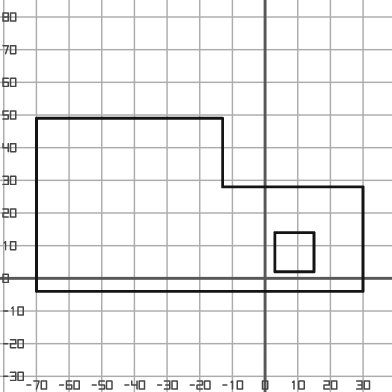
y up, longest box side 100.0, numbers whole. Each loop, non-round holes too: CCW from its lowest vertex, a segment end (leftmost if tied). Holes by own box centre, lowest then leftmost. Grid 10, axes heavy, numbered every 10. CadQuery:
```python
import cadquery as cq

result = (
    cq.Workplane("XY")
    .moveTo(-70.0, -4.0)
    .lineTo(30.0, -4.0)
    .lineTo(30.0, 28.0)
    .lineTo(-13.0, 28.0)
    .lineTo(-13.0, 49.0)
    .lineTo(-70.0, 49.0)
    .close()
    .moveTo(3.0, 2.0)
    .lineTo(15.0, 2.0)
    .lineTo(15.0, 14.0)
    .lineTo(3.0, 14.0)
    .close()
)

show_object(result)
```